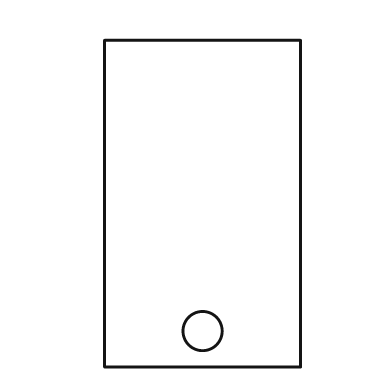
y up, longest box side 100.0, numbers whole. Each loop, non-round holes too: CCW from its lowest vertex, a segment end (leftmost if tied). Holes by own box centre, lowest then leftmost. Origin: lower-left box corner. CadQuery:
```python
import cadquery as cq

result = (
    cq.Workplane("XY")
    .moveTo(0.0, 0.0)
    .lineTo(60.0, 0.0)
    .lineTo(60.0, 100.0)
    .lineTo(0.0, 100.0)
    .close()
    .moveTo(30.0, 11.0)
    .circle(6.0)
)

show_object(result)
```